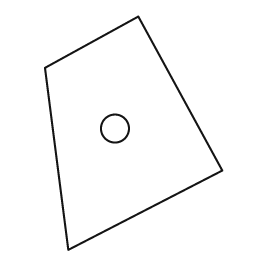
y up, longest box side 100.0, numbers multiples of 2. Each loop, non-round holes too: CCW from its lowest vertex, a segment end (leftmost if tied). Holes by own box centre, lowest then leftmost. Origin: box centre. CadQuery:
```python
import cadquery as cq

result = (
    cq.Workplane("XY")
    .moveTo(-28.0, -50.0)
    .lineTo(38.0, -16.0)
    .lineTo(2.0, 50.0)
    .lineTo(-38.0, 28.0)
    .close()
    .moveTo(-8.0, 2.0)
    .circle(6.0)
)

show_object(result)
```